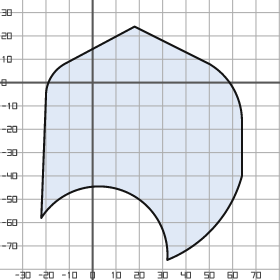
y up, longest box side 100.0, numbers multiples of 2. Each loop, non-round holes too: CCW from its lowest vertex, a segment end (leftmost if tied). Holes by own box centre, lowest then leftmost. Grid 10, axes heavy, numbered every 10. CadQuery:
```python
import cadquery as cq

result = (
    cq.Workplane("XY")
    .moveTo(32.0, -76.0)
    .threePointArc((52.0, -62.0), (64.0, -40.0))
    .lineTo(64.0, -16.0)
    .threePointArc((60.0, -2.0), (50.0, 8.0))
    .lineTo(18.0, 24.0)
    .lineTo(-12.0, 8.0)
    .threePointArc((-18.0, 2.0), (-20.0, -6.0))
    .lineTo(-22.0, -58.0)
    .threePointArc((12.0, -46.0), (32.0, -76.0))
    .close()
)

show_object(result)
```